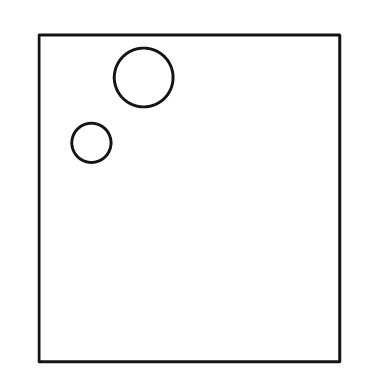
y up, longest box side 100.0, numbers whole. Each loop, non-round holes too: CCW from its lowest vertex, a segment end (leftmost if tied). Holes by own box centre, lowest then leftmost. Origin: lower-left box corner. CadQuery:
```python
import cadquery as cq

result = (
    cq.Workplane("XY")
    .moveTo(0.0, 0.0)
    .lineTo(92.0, 0.0)
    .lineTo(92.0, 100.0)
    .lineTo(0.0, 100.0)
    .close()
    .moveTo(16.0, 67.0)
    .circle(6.0)
    .moveTo(32.0, 87.0)
    .circle(9.0)
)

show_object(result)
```